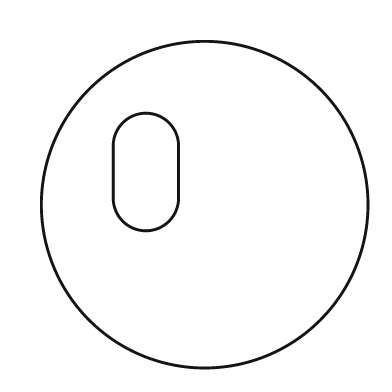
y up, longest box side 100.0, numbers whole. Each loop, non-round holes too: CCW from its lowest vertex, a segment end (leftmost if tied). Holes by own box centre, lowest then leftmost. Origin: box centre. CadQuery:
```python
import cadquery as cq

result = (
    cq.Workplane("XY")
    .moveTo(0.0, 0.0)
    .circle(50.0)
    .moveTo(-28.0, 2.0)
    .threePointArc((-18.0, -8.0), (-8.0, 2.0))
    .lineTo(-8.0, 18.0)
    .threePointArc((-18.0, 28.0), (-28.0, 18.0))
    .close()
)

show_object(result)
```